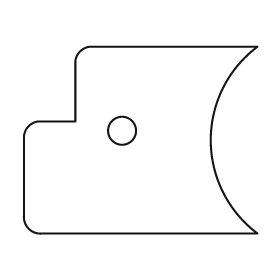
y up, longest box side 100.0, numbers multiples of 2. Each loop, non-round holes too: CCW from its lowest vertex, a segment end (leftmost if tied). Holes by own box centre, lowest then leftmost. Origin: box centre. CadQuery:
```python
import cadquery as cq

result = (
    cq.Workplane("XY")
    .moveTo(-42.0, -40.0)
    .lineTo(50.0, -40.0)
    .threePointArc((30.0, 0.0), (50.0, 40.0))
    .lineTo(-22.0, 40.0)
    .threePointArc((-26.0, 38.0), (-28.0, 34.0))
    .lineTo(-28.0, 8.0)
    .lineTo(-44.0, 8.0)
    .threePointArc((-48.0, 6.0), (-50.0, 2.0))
    .lineTo(-50.0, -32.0)
    .threePointArc((-48.0, -38.0), (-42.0, -40.0))
    .close()
    .moveTo(-8.0, 4.0)
    .circle(6.0)
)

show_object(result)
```